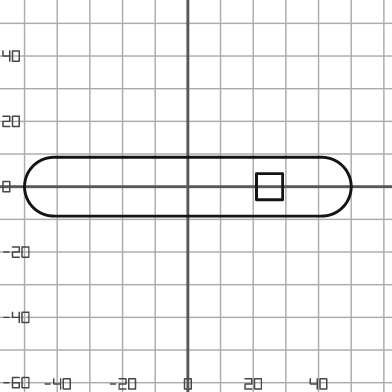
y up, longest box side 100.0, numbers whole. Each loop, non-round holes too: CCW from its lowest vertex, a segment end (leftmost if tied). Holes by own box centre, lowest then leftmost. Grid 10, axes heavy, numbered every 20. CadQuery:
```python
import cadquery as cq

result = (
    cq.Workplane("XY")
    .moveTo(-41.0, -9.0)
    .lineTo(41.0, -9.0)
    .threePointArc((50.0, 0.0), (41.0, 9.0))
    .lineTo(-41.0, 9.0)
    .threePointArc((-50.0, 0.0), (-41.0, -9.0))
    .close()
    .moveTo(21.0, -4.0)
    .lineTo(29.0, -4.0)
    .lineTo(29.0, 4.0)
    .lineTo(21.0, 4.0)
    .close()
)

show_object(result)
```